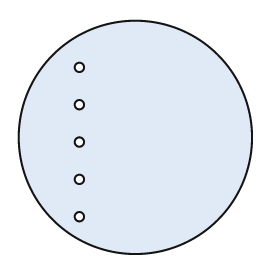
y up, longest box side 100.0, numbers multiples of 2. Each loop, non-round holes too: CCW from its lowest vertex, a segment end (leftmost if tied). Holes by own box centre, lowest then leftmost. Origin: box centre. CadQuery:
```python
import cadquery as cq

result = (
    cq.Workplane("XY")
    .moveTo(0.0, 0.0)
    .circle(50.0)
    .moveTo(-24.0, -34.0)
    .circle(2.0)
    .moveTo(-24.0, -18.0)
    .circle(2.0)
    .moveTo(-24.0, -2.0)
    .circle(2.0)
    .moveTo(-24.0, 14.0)
    .circle(2.0)
    .moveTo(-24.0, 30.0)
    .circle(2.0)
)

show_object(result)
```